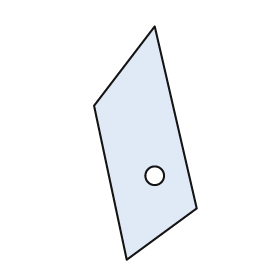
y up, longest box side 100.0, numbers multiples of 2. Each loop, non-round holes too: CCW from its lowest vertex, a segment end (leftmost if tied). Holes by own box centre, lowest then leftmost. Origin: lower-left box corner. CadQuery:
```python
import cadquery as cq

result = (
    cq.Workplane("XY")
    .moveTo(14.0, 0.0)
    .lineTo(44.0, 22.0)
    .lineTo(26.0, 100.0)
    .lineTo(0.0, 66.0)
    .close()
    .moveTo(26.0, 36.0)
    .circle(4.0)
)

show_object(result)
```